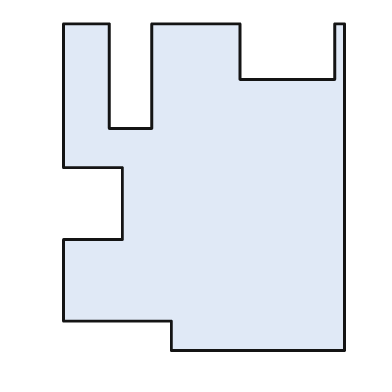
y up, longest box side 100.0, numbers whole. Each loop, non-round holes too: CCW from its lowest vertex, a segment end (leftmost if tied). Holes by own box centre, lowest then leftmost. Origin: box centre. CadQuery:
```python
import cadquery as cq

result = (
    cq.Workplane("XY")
    .moveTo(-10.0, -50.0)
    .lineTo(43.0, -50.0)
    .lineTo(43.0, 50.0)
    .lineTo(40.0, 50.0)
    .lineTo(40.0, 33.0)
    .lineTo(11.0, 33.0)
    .lineTo(11.0, 50.0)
    .lineTo(-16.0, 50.0)
    .lineTo(-16.0, 18.0)
    .lineTo(-29.0, 18.0)
    .lineTo(-29.0, 50.0)
    .lineTo(-43.0, 50.0)
    .lineTo(-43.0, 6.0)
    .lineTo(-25.0, 6.0)
    .lineTo(-25.0, -16.0)
    .lineTo(-43.0, -16.0)
    .lineTo(-43.0, -41.0)
    .lineTo(-10.0, -41.0)
    .close()
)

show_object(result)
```